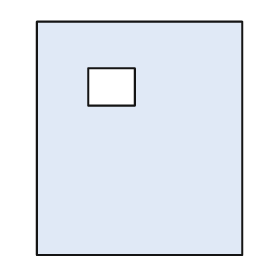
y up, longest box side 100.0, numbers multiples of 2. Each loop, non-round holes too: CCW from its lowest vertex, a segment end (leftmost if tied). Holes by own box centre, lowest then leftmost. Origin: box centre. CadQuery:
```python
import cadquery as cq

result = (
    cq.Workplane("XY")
    .moveTo(-44.0, -50.0)
    .lineTo(44.0, -50.0)
    .lineTo(44.0, 50.0)
    .lineTo(-44.0, 50.0)
    .close()
    .moveTo(-22.0, 14.0)
    .lineTo(-2.0, 14.0)
    .lineTo(-2.0, 30.0)
    .lineTo(-22.0, 30.0)
    .close()
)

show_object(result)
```